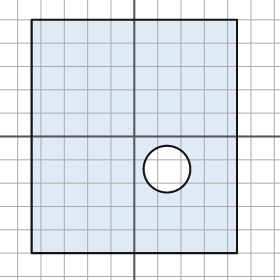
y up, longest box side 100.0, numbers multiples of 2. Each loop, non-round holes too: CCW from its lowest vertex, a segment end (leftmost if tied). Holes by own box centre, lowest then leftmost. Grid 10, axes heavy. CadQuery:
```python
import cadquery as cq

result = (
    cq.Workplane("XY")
    .moveTo(-44.0, -50.0)
    .lineTo(44.0, -50.0)
    .lineTo(44.0, 50.0)
    .lineTo(-44.0, 50.0)
    .close()
    .moveTo(14.0, -14.0)
    .circle(10.0)
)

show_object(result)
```